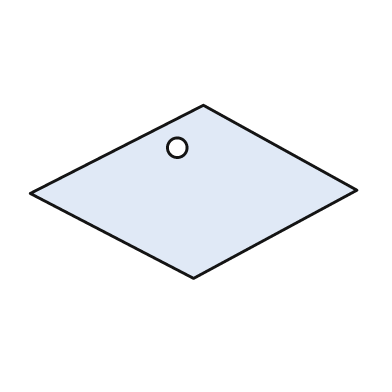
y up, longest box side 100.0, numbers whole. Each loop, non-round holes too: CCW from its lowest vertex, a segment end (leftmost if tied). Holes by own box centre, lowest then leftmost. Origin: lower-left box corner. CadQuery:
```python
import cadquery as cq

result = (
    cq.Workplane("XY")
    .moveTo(50.0, 0.0)
    .lineTo(100.0, 27.0)
    .lineTo(53.0, 53.0)
    .lineTo(0.0, 26.0)
    .close()
    .moveTo(45.0, 40.0)
    .circle(3.0)
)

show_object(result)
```